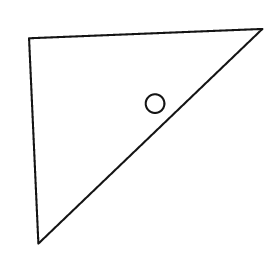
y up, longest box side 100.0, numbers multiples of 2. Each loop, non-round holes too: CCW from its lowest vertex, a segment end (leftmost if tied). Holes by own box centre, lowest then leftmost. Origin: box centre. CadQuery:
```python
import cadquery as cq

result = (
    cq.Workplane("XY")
    .moveTo(-46.0, -46.0)
    .lineTo(50.0, 46.0)
    .lineTo(-50.0, 42.0)
    .close()
    .moveTo(4.0, 14.0)
    .circle(4.0)
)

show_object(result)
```